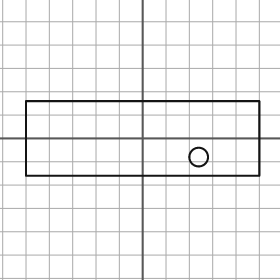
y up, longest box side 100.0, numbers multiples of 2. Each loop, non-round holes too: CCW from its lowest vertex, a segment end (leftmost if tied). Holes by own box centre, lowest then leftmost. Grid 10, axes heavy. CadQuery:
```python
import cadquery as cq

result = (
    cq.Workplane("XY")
    .moveTo(-50.0, -16.0)
    .lineTo(50.0, -16.0)
    .lineTo(50.0, 16.0)
    .lineTo(-50.0, 16.0)
    .close()
    .moveTo(24.0, -8.0)
    .circle(4.0)
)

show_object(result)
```